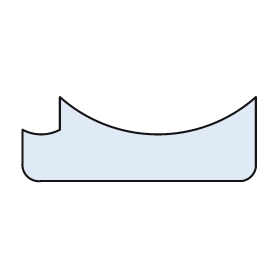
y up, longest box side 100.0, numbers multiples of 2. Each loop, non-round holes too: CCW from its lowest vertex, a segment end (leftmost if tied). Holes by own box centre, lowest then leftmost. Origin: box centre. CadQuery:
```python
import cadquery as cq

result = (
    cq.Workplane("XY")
    .moveTo(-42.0, -18.0)
    .lineTo(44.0, -18.0)
    .threePointArc((48.0, -16.0), (50.0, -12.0))
    .lineTo(50.0, 18.0)
    .threePointArc((8.0, 2.0), (-34.0, 18.0))
    .lineTo(-34.0, 4.0)
    .threePointArc((-42.0, 2.0), (-50.0, 4.0))
    .lineTo(-50.0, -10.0)
    .threePointArc((-48.0, -16.0), (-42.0, -18.0))
    .close()
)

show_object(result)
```